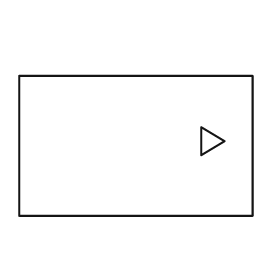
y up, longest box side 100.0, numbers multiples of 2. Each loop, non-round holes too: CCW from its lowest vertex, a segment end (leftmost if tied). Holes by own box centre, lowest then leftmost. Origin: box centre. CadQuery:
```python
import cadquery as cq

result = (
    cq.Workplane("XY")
    .moveTo(-50.0, -30.0)
    .lineTo(50.0, -30.0)
    .lineTo(50.0, 30.0)
    .lineTo(-50.0, 30.0)
    .close()
    .moveTo(28.0, -4.0)
    .lineTo(38.0, 2.0)
    .lineTo(28.0, 8.0)
    .close()
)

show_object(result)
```